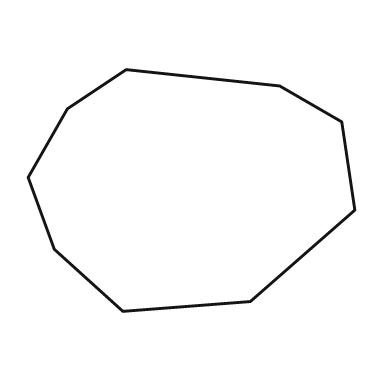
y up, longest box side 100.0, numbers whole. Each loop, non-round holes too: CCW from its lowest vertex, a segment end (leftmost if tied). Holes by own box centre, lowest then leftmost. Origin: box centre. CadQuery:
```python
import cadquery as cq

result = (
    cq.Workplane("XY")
    .moveTo(-21.0, -37.0)
    .lineTo(18.0, -34.0)
    .lineTo(50.0, -6.0)
    .lineTo(46.0, 21.0)
    .lineTo(27.0, 32.0)
    .lineTo(-20.0, 37.0)
    .lineTo(-38.0, 25.0)
    .lineTo(-50.0, 4.0)
    .lineTo(-42.0, -18.0)
    .close()
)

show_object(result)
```